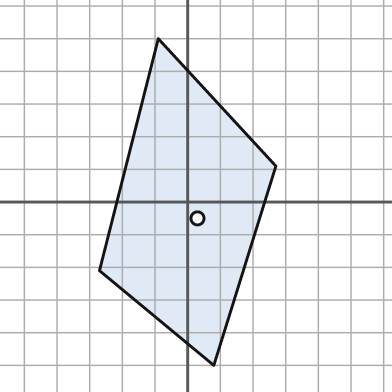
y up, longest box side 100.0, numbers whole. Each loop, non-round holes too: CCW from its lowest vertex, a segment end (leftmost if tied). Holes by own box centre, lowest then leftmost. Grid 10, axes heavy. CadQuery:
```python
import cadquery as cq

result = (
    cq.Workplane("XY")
    .moveTo(8.0, -50.0)
    .lineTo(27.0, 11.0)
    .lineTo(-9.0, 50.0)
    .lineTo(-27.0, -21.0)
    .close()
    .moveTo(3.0, -5.0)
    .circle(2.0)
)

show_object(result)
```